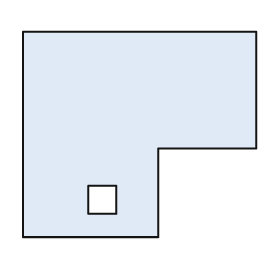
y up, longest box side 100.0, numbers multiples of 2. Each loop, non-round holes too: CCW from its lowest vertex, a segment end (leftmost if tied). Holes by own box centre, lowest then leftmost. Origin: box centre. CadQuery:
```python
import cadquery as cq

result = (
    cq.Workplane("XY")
    .moveTo(-50.0, -44.0)
    .lineTo(8.0, -44.0)
    .lineTo(8.0, -6.0)
    .lineTo(50.0, -6.0)
    .lineTo(50.0, 44.0)
    .lineTo(-50.0, 44.0)
    .close()
    .moveTo(-22.0, -34.0)
    .lineTo(-10.0, -34.0)
    .lineTo(-10.0, -22.0)
    .lineTo(-22.0, -22.0)
    .close()
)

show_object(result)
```